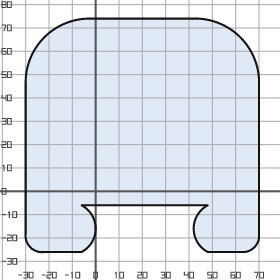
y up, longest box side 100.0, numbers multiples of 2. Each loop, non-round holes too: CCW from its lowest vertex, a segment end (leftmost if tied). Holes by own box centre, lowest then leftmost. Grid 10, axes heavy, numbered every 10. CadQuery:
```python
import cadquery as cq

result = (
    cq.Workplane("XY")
    .moveTo(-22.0, -26.0)
    .lineTo(-6.0, -26.0)
    .threePointArc((0.0, -16.0), (-6.0, -6.0))
    .lineTo(48.0, -6.0)
    .threePointArc((42.0, -16.0), (48.0, -26.0))
    .lineTo(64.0, -26.0)
    .threePointArc((68.0, -24.0), (70.0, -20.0))
    .lineTo(70.0, 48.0)
    .threePointArc((62.0, 66.0), (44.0, 74.0))
    .lineTo(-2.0, 74.0)
    .threePointArc((-22.0, 66.0), (-30.0, 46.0))
    .lineTo(-30.0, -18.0)
    .threePointArc((-28.0, -24.0), (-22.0, -26.0))
    .close()
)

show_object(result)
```